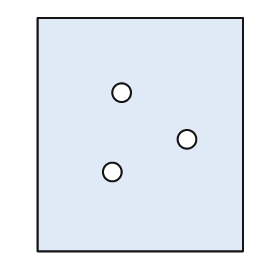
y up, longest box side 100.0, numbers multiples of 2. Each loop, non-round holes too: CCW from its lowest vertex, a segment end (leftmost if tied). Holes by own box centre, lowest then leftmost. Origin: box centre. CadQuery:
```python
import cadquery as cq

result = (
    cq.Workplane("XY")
    .moveTo(-44.0, -50.0)
    .lineTo(44.0, -50.0)
    .lineTo(44.0, 50.0)
    .lineTo(-44.0, 50.0)
    .close()
    .moveTo(-12.0, -16.0)
    .circle(4.0)
    .moveTo(20.0, -2.0)
    .circle(4.0)
    .moveTo(-8.0, 18.0)
    .circle(4.0)
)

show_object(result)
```